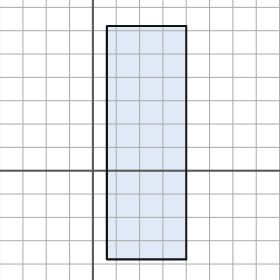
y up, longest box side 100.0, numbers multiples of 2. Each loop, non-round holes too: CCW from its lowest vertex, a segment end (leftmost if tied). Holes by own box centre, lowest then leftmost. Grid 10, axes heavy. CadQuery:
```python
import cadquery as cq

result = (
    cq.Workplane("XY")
    .moveTo(6.0, -38.0)
    .lineTo(40.0, -38.0)
    .lineTo(40.0, 62.0)
    .lineTo(6.0, 62.0)
    .close()
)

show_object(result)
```